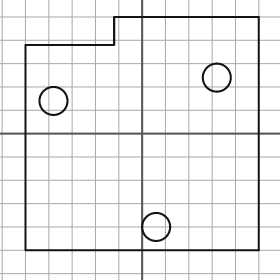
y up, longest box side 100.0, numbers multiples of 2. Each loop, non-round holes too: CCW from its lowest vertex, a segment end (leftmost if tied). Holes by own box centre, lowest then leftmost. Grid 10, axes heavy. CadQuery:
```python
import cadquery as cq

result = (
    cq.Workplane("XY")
    .moveTo(-50.0, -50.0)
    .lineTo(50.0, -50.0)
    .lineTo(50.0, 50.0)
    .lineTo(-12.0, 50.0)
    .lineTo(-12.0, 38.0)
    .lineTo(-50.0, 38.0)
    .close()
    .moveTo(6.0, -40.0)
    .circle(6.0)
    .moveTo(-38.0, 14.0)
    .circle(6.0)
    .moveTo(32.0, 24.0)
    .circle(6.0)
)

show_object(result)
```